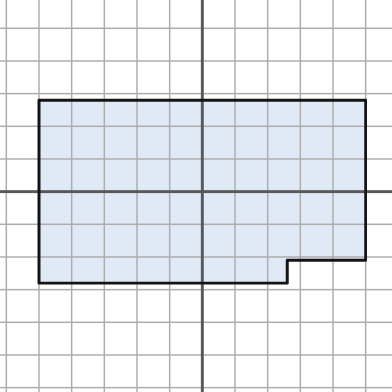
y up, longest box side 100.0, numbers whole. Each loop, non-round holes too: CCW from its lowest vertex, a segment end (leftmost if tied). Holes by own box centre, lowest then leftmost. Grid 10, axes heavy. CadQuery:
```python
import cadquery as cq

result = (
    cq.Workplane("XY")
    .moveTo(-50.0, -28.0)
    .lineTo(26.0, -28.0)
    .lineTo(26.0, -21.0)
    .lineTo(50.0, -21.0)
    .lineTo(50.0, 28.0)
    .lineTo(-50.0, 28.0)
    .close()
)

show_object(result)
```